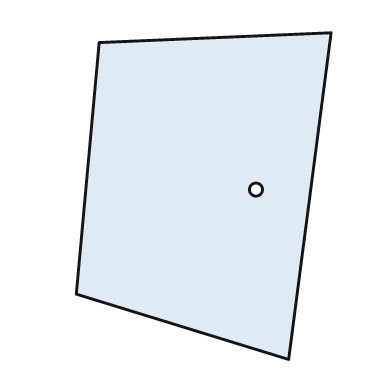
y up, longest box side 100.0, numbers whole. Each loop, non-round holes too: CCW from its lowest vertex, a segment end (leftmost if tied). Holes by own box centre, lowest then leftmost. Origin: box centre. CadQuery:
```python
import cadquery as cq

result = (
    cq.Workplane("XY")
    .moveTo(26.0, -50.0)
    .lineTo(39.0, 50.0)
    .lineTo(-32.0, 47.0)
    .lineTo(-39.0, -30.0)
    .close()
    .moveTo(16.0, 2.0)
    .circle(2.0)
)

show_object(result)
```